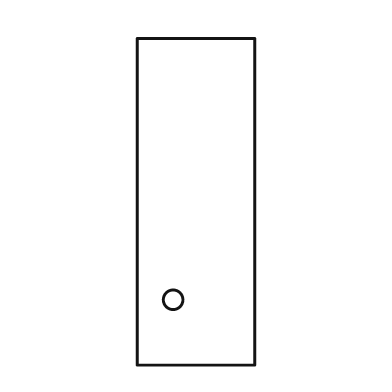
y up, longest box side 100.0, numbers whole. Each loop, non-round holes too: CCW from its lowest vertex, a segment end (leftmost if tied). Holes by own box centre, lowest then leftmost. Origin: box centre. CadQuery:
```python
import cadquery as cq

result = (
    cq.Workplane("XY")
    .moveTo(-18.0, -50.0)
    .lineTo(18.0, -50.0)
    .lineTo(18.0, 50.0)
    .lineTo(-18.0, 50.0)
    .close()
    .moveTo(-7.0, -30.0)
    .circle(3.0)
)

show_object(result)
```